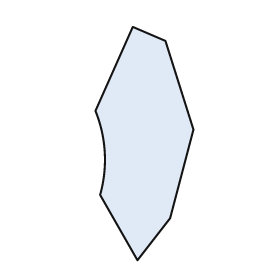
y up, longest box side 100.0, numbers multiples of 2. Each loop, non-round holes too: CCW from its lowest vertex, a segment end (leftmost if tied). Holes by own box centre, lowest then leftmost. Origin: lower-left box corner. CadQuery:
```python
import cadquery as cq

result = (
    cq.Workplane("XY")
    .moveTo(18.0, 0.0)
    .lineTo(32.0, 18.0)
    .lineTo(42.0, 56.0)
    .lineTo(30.0, 94.0)
    .lineTo(16.0, 100.0)
    .lineTo(0.0, 64.0)
    .threePointArc((4.0, 46.0), (2.0, 28.0))
    .close()
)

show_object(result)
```